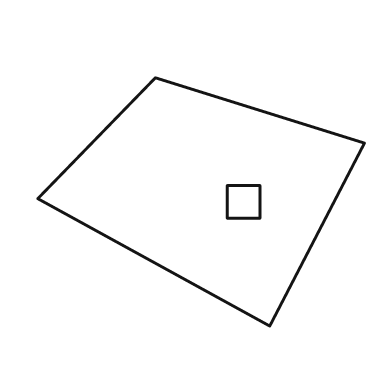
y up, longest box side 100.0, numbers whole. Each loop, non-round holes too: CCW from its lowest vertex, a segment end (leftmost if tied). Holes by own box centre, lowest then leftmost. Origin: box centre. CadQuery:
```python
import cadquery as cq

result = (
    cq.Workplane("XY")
    .moveTo(21.0, -38.0)
    .lineTo(50.0, 18.0)
    .lineTo(-14.0, 38.0)
    .lineTo(-50.0, 1.0)
    .close()
    .moveTo(8.0, -5.0)
    .lineTo(18.0, -5.0)
    .lineTo(18.0, 5.0)
    .lineTo(8.0, 5.0)
    .close()
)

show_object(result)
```